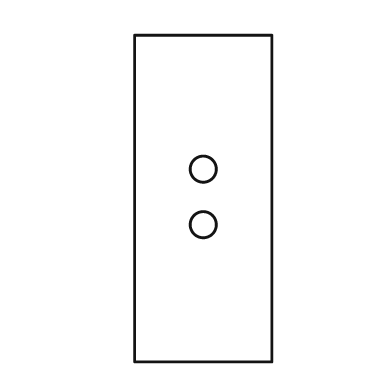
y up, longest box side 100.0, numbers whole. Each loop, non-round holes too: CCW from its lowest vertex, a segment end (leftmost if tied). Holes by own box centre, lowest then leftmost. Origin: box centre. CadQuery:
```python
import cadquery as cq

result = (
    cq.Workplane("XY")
    .moveTo(-21.0, -50.0)
    .lineTo(21.0, -50.0)
    .lineTo(21.0, 50.0)
    .lineTo(-21.0, 50.0)
    .close()
    .moveTo(0.0, -8.0)
    .circle(4.0)
    .moveTo(0.0, 9.0)
    .circle(4.0)
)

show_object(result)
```